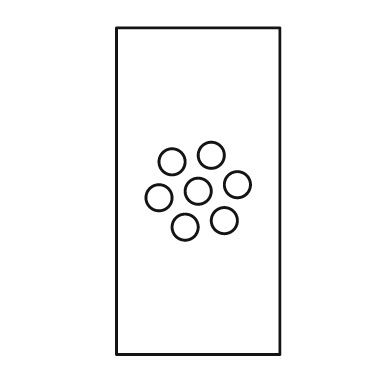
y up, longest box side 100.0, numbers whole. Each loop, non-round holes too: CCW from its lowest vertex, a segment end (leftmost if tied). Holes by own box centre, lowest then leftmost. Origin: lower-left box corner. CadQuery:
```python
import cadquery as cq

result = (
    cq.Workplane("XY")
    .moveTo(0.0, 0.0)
    .lineTo(50.0, 0.0)
    .lineTo(50.0, 100.0)
    .lineTo(0.0, 100.0)
    .close()
    .moveTo(21.0, 39.0)
    .circle(4.0)
    .moveTo(33.0, 41.0)
    .circle(4.0)
    .moveTo(13.0, 48.0)
    .circle(4.0)
    .moveTo(25.0, 50.0)
    .circle(4.0)
    .moveTo(37.0, 52.0)
    .circle(4.0)
    .moveTo(17.0, 59.0)
    .circle(4.0)
    .moveTo(29.0, 61.0)
    .circle(4.0)
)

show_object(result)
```